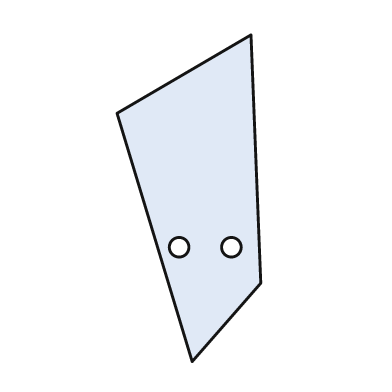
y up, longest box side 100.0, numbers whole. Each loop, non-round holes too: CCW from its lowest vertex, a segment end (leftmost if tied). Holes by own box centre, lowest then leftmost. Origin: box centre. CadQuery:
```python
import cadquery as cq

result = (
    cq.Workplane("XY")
    .moveTo(1.0, -50.0)
    .lineTo(22.0, -26.0)
    .lineTo(19.0, 50.0)
    .lineTo(-22.0, 26.0)
    .close()
    .moveTo(-3.0, -15.0)
    .circle(3.0)
    .moveTo(13.0, -15.0)
    .circle(3.0)
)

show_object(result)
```